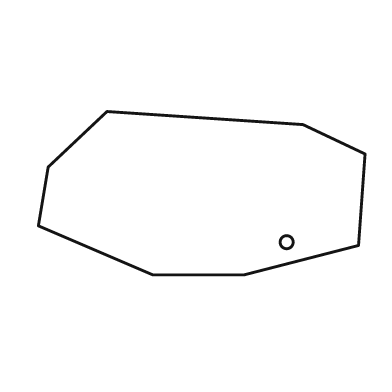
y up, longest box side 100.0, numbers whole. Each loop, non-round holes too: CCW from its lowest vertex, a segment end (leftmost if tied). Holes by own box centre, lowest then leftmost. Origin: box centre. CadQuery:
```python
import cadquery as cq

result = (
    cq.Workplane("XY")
    .moveTo(-15.0, -25.0)
    .lineTo(13.0, -25.0)
    .lineTo(48.0, -16.0)
    .lineTo(50.0, 12.0)
    .lineTo(31.0, 21.0)
    .lineTo(-29.0, 25.0)
    .lineTo(-47.0, 8.0)
    .lineTo(-50.0, -10.0)
    .close()
    .moveTo(26.0, -15.0)
    .circle(2.0)
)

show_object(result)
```